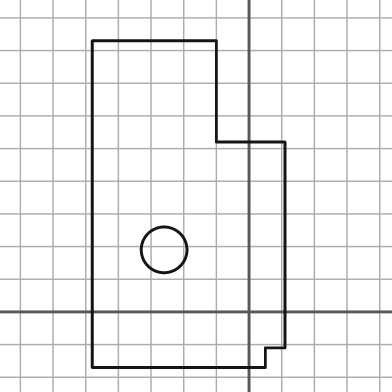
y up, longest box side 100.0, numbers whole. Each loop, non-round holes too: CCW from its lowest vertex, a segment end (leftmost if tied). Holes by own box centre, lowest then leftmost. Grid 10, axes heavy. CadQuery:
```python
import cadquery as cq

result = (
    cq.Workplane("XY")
    .moveTo(-48.0, -17.0)
    .lineTo(5.0, -17.0)
    .lineTo(5.0, -11.0)
    .lineTo(11.0, -11.0)
    .lineTo(11.0, 52.0)
    .lineTo(-10.0, 52.0)
    .lineTo(-10.0, 83.0)
    .lineTo(-48.0, 83.0)
    .close()
    .moveTo(-26.0, 19.0)
    .circle(7.0)
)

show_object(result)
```